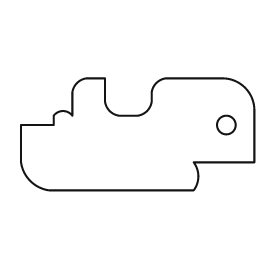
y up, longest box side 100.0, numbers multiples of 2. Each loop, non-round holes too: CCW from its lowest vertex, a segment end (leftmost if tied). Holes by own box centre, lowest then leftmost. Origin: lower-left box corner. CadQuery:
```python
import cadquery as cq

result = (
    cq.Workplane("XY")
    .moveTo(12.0, 0.0)
    .lineTo(74.0, 0.0)
    .threePointArc((76.0, 6.0), (74.0, 12.0))
    .lineTo(100.0, 12.0)
    .lineTo(100.0, 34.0)
    .threePointArc((96.0, 44.0), (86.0, 48.0))
    .lineTo(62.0, 48.0)
    .threePointArc((58.0, 46.0), (56.0, 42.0))
    .lineTo(56.0, 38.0)
    .threePointArc((54.0, 34.0), (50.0, 32.0))
    .lineTo(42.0, 32.0)
    .threePointArc((38.0, 34.0), (36.0, 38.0))
    .lineTo(36.0, 48.0)
    .lineTo(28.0, 48.0)
    .threePointArc((24.0, 46.0), (22.0, 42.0))
    .lineTo(22.0, 32.0)
    .threePointArc((18.0, 34.0), (14.0, 32.0))
    .lineTo(14.0, 28.0)
    .lineTo(0.0, 28.0)
    .lineTo(0.0, 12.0)
    .threePointArc((4.0, 4.0), (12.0, 0.0))
    .close()
    .moveTo(88.0, 28.0)
    .circle(4.0)
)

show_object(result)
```